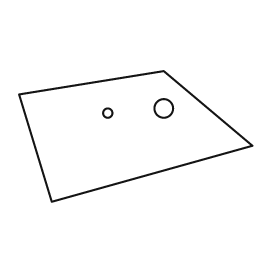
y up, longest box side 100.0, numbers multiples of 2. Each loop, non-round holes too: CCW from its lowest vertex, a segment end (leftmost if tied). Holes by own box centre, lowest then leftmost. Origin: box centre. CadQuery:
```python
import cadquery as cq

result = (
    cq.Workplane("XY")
    .moveTo(-36.0, -28.0)
    .lineTo(50.0, -4.0)
    .lineTo(12.0, 28.0)
    .lineTo(-50.0, 18.0)
    .close()
    .moveTo(-12.0, 10.0)
    .circle(2.0)
    .moveTo(12.0, 12.0)
    .circle(4.0)
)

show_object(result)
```